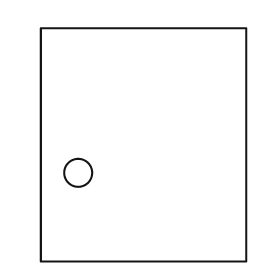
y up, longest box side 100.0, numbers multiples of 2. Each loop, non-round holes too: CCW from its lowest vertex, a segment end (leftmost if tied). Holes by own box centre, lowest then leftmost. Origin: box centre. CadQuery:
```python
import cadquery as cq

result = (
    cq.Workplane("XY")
    .moveTo(-44.0, -50.0)
    .lineTo(44.0, -50.0)
    .lineTo(44.0, 50.0)
    .lineTo(-44.0, 50.0)
    .close()
    .moveTo(-28.0, -12.0)
    .circle(6.0)
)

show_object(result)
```